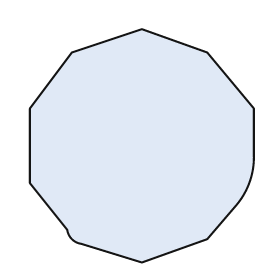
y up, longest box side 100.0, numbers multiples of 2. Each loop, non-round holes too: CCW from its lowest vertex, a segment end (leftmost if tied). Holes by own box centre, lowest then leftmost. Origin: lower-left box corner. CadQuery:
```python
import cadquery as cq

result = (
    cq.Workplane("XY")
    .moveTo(48.0, 0.0)
    .lineTo(76.0, 10.0)
    .lineTo(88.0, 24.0)
    .threePointArc((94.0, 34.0), (96.0, 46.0))
    .lineTo(96.0, 66.0)
    .lineTo(76.0, 90.0)
    .lineTo(48.0, 100.0)
    .lineTo(18.0, 90.0)
    .lineTo(0.0, 66.0)
    .lineTo(0.0, 34.0)
    .lineTo(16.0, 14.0)
    .threePointArc((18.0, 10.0), (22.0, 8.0))
    .close()
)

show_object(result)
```